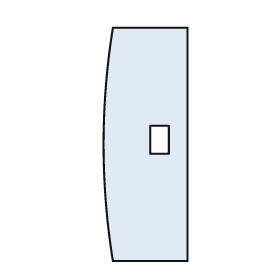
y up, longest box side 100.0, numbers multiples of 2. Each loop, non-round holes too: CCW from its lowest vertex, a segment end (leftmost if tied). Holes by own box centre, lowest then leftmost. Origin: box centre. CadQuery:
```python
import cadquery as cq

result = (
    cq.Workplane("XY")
    .moveTo(-14.0, -50.0)
    .lineTo(18.0, -50.0)
    .lineTo(18.0, 50.0)
    .lineTo(-14.0, 50.0)
    .threePointArc((-18.0, 0.0), (-14.0, -50.0))
    .close()
    .moveTo(2.0, -4.0)
    .lineTo(10.0, -4.0)
    .lineTo(10.0, 8.0)
    .lineTo(2.0, 8.0)
    .close()
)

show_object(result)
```